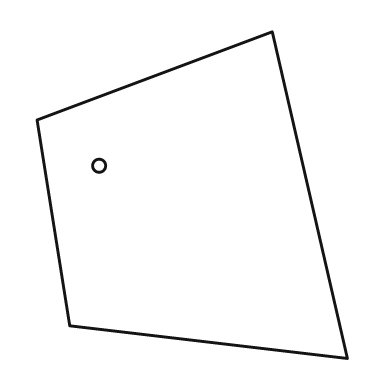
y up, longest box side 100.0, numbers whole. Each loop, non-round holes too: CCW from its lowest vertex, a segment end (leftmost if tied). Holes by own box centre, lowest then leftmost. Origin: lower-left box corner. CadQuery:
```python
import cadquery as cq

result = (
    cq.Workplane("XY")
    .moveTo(95.0, 0.0)
    .lineTo(72.0, 100.0)
    .lineTo(0.0, 73.0)
    .lineTo(10.0, 10.0)
    .close()
    .moveTo(19.0, 59.0)
    .circle(2.0)
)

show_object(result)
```